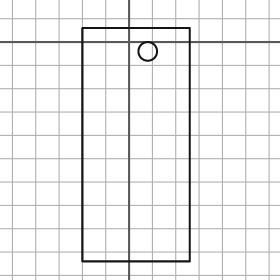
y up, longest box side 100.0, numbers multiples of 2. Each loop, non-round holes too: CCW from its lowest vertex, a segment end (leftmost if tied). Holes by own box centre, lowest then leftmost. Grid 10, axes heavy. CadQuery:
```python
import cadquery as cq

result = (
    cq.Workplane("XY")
    .moveTo(-20.0, -94.0)
    .lineTo(26.0, -94.0)
    .lineTo(26.0, 6.0)
    .lineTo(-20.0, 6.0)
    .close()
    .moveTo(8.0, -4.0)
    .circle(4.0)
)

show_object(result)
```